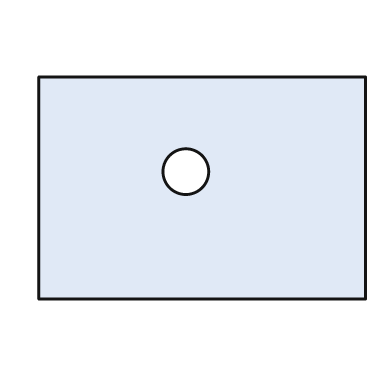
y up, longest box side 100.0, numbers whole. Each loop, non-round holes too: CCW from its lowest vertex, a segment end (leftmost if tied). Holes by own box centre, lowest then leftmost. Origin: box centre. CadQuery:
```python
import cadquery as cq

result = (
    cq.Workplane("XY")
    .moveTo(-50.0, -34.0)
    .lineTo(50.0, -34.0)
    .lineTo(50.0, 34.0)
    .lineTo(-50.0, 34.0)
    .close()
    .moveTo(-5.0, 5.0)
    .circle(7.0)
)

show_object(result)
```